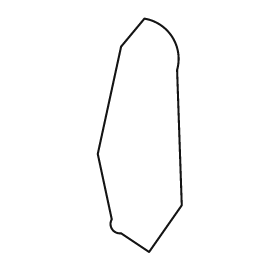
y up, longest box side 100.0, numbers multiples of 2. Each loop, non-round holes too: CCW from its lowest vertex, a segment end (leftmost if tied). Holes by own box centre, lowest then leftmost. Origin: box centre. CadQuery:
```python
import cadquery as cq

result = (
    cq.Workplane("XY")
    .moveTo(4.0, -50.0)
    .lineTo(18.0, -30.0)
    .lineTo(16.0, 28.0)
    .threePointArc((14.0, 42.0), (2.0, 50.0))
    .lineTo(-8.0, 38.0)
    .lineTo(-18.0, -8.0)
    .lineTo(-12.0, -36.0)
    .threePointArc((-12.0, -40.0), (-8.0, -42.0))
    .close()
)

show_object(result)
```